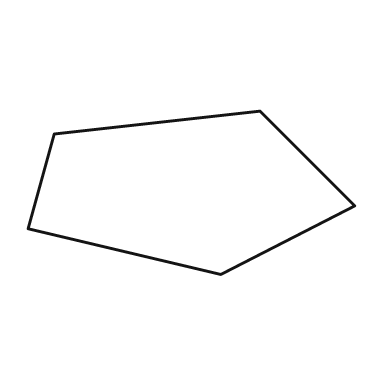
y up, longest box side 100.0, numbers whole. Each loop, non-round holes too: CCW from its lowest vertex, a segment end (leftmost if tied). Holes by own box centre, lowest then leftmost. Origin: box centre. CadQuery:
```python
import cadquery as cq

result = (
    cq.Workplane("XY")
    .moveTo(9.0, -25.0)
    .lineTo(50.0, -4.0)
    .lineTo(21.0, 25.0)
    .lineTo(-42.0, 18.0)
    .lineTo(-50.0, -11.0)
    .close()
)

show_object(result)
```